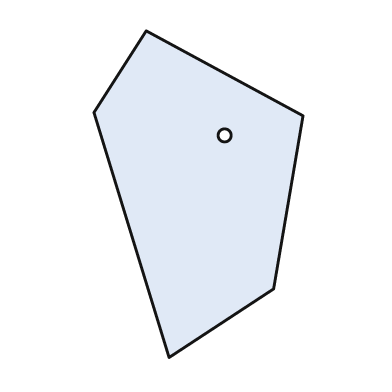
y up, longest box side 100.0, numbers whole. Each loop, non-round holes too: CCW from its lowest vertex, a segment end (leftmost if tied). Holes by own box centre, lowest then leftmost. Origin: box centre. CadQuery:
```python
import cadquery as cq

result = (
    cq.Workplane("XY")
    .moveTo(-9.0, -50.0)
    .lineTo(23.0, -29.0)
    .lineTo(32.0, 24.0)
    .lineTo(-16.0, 50.0)
    .lineTo(-32.0, 25.0)
    .close()
    .moveTo(8.0, 18.0)
    .circle(2.0)
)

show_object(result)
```